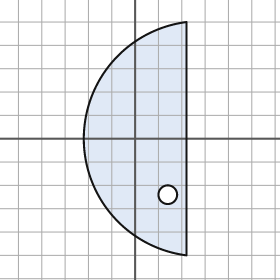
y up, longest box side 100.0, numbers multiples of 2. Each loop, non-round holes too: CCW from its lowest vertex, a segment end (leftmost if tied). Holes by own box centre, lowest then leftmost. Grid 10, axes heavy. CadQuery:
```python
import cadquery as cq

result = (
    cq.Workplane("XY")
    .moveTo(22.0, -50.0)
    .lineTo(22.0, 50.0)
    .threePointArc((-22.0, 0.0), (22.0, -50.0))
    .close()
    .moveTo(14.0, -24.0)
    .circle(4.0)
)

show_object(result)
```